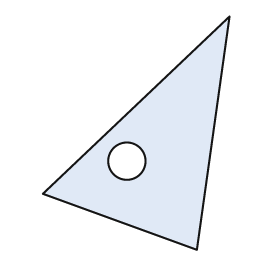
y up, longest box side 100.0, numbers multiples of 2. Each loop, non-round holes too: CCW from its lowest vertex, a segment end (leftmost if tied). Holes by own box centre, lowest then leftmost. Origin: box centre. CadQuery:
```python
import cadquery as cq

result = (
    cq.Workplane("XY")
    .moveTo(26.0, -50.0)
    .lineTo(40.0, 50.0)
    .lineTo(-40.0, -26.0)
    .close()
    .moveTo(-4.0, -12.0)
    .circle(8.0)
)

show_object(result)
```